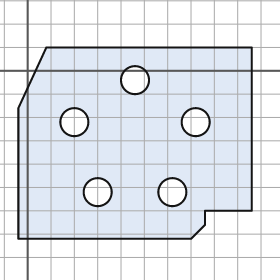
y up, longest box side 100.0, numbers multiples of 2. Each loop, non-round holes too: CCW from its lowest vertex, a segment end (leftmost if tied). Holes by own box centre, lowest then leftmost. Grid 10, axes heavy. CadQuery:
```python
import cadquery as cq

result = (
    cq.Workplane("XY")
    .moveTo(-4.0, -72.0)
    .lineTo(70.0, -72.0)
    .lineTo(76.0, -66.0)
    .lineTo(76.0, -60.0)
    .lineTo(96.0, -60.0)
    .lineTo(96.0, 10.0)
    .lineTo(8.0, 10.0)
    .lineTo(-4.0, -16.0)
    .close()
    .moveTo(30.0, -52.0)
    .circle(6.0)
    .moveTo(62.0, -52.0)
    .circle(6.0)
    .moveTo(20.0, -22.0)
    .circle(6.0)
    .moveTo(72.0, -22.0)
    .circle(6.0)
    .moveTo(46.0, -4.0)
    .circle(6.0)
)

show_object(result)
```